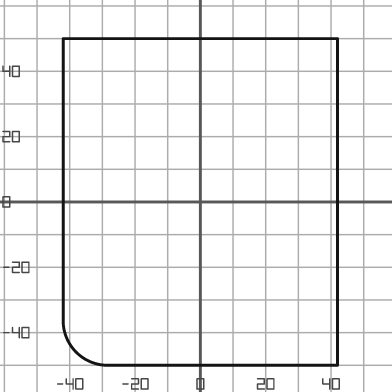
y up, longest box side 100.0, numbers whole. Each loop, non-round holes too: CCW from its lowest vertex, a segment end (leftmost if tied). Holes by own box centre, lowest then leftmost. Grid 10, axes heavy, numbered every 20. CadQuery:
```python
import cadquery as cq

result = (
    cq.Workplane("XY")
    .moveTo(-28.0, -50.0)
    .lineTo(42.0, -50.0)
    .lineTo(42.0, 50.0)
    .lineTo(-42.0, 50.0)
    .lineTo(-42.0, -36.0)
    .threePointArc((-38.0, -46.0), (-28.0, -50.0))
    .close()
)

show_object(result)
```